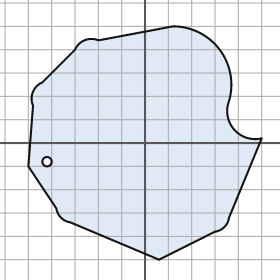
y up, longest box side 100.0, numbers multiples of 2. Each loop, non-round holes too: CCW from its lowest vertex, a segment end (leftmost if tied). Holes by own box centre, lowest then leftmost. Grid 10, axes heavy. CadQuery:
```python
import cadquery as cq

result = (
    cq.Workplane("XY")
    .moveTo(6.0, -50.0)
    .lineTo(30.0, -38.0)
    .threePointArc((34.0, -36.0), (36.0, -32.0))
    .lineTo(50.0, 2.0)
    .threePointArc((38.0, 6.0), (36.0, 18.0))
    .threePointArc((32.0, 40.0), (12.0, 50.0))
    .lineTo(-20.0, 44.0)
    .threePointArc((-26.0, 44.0), (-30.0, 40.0))
    .lineTo(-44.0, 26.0)
    .threePointArc((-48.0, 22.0), (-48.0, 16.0))
    .lineTo(-50.0, -10.0)
    .lineTo(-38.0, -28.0)
    .threePointArc((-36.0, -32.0), (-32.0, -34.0))
    .close()
    .moveTo(-42.0, -8.0)
    .circle(2.0)
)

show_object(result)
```